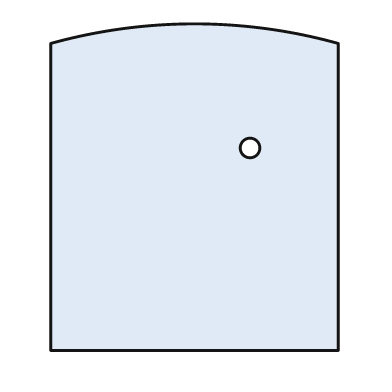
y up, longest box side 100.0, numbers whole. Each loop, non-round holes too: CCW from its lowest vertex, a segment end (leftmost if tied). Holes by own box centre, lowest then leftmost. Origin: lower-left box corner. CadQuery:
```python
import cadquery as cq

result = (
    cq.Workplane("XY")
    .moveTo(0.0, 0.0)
    .lineTo(88.0, 0.0)
    .lineTo(88.0, 94.0)
    .threePointArc((44.0, 100.0), (0.0, 94.0))
    .close()
    .moveTo(61.0, 62.0)
    .circle(3.0)
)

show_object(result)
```